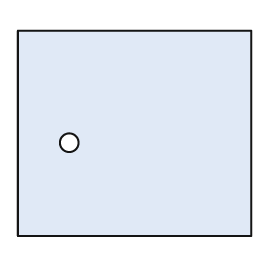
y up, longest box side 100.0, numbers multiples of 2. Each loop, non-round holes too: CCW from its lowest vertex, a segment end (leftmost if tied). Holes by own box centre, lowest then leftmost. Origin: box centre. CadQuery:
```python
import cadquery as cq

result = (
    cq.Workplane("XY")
    .moveTo(-50.0, -44.0)
    .lineTo(50.0, -44.0)
    .lineTo(50.0, 44.0)
    .lineTo(-50.0, 44.0)
    .close()
    .moveTo(-28.0, -4.0)
    .circle(4.0)
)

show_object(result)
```